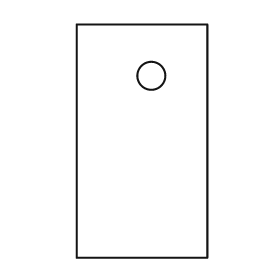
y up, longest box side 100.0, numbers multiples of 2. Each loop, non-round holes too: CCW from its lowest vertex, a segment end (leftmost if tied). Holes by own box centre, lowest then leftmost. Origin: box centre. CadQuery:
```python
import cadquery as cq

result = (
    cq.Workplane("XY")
    .moveTo(-28.0, -50.0)
    .lineTo(28.0, -50.0)
    .lineTo(28.0, 50.0)
    .lineTo(-28.0, 50.0)
    .close()
    .moveTo(4.0, 28.0)
    .circle(6.0)
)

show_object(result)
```